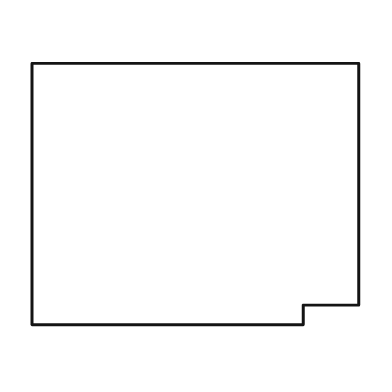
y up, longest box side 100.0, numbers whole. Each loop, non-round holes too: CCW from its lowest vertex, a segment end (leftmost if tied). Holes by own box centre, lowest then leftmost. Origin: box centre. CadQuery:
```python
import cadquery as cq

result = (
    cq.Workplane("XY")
    .moveTo(-50.0, -40.0)
    .lineTo(33.0, -40.0)
    .lineTo(33.0, -34.0)
    .lineTo(50.0, -34.0)
    .lineTo(50.0, 40.0)
    .lineTo(-50.0, 40.0)
    .close()
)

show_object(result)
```